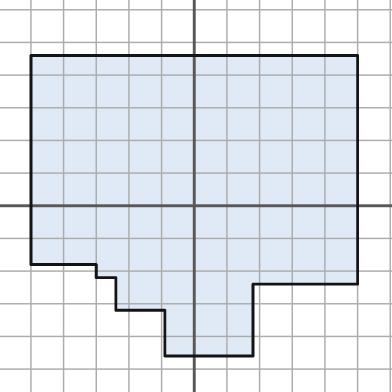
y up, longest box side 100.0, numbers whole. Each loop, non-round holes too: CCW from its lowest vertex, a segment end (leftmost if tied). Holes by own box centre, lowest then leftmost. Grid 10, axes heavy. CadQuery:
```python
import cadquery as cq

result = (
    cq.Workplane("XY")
    .moveTo(-9.0, -46.0)
    .lineTo(18.0, -46.0)
    .lineTo(18.0, -24.0)
    .lineTo(50.0, -24.0)
    .lineTo(50.0, 46.0)
    .lineTo(-50.0, 46.0)
    .lineTo(-50.0, -18.0)
    .lineTo(-30.0, -18.0)
    .lineTo(-30.0, -22.0)
    .lineTo(-24.0, -22.0)
    .lineTo(-24.0, -32.0)
    .lineTo(-9.0, -32.0)
    .close()
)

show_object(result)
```